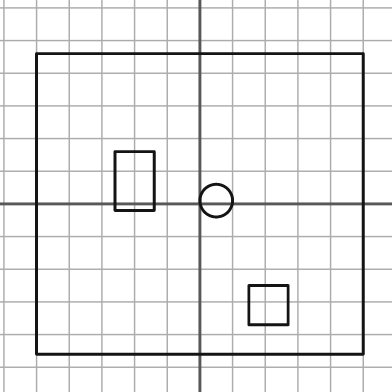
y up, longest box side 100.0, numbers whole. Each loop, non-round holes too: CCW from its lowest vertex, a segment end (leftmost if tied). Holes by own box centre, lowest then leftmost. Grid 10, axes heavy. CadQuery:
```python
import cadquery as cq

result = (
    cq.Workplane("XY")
    .moveTo(-50.0, -46.0)
    .lineTo(50.0, -46.0)
    .lineTo(50.0, 46.0)
    .lineTo(-50.0, 46.0)
    .close()
    .moveTo(15.0, -37.0)
    .lineTo(27.0, -37.0)
    .lineTo(27.0, -25.0)
    .lineTo(15.0, -25.0)
    .close()
    .moveTo(5.0, 1.0)
    .circle(5.0)
    .moveTo(-26.0, -2.0)
    .lineTo(-14.0, -2.0)
    .lineTo(-14.0, 16.0)
    .lineTo(-26.0, 16.0)
    .close()
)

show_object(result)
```